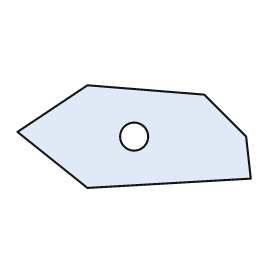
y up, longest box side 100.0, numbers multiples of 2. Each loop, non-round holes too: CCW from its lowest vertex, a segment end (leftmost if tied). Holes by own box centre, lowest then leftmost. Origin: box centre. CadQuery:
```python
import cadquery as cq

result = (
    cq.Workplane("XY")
    .moveTo(-20.0, -22.0)
    .lineTo(50.0, -18.0)
    .lineTo(48.0, 0.0)
    .lineTo(30.0, 18.0)
    .lineTo(-20.0, 22.0)
    .lineTo(-50.0, 2.0)
    .close()
    .moveTo(0.0, 0.0)
    .circle(6.0)
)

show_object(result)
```